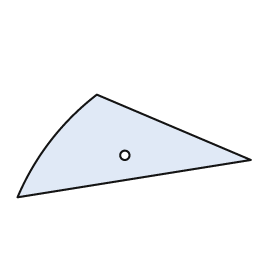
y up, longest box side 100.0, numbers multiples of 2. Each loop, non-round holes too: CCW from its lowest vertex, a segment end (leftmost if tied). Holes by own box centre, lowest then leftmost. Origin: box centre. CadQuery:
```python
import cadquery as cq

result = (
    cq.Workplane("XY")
    .moveTo(-50.0, -22.0)
    .lineTo(50.0, -6.0)
    .lineTo(-16.0, 22.0)
    .threePointArc((-36.0, 2.0), (-50.0, -22.0))
    .close()
    .moveTo(-4.0, -4.0)
    .circle(2.0)
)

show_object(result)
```